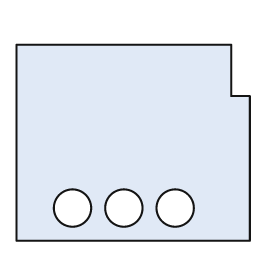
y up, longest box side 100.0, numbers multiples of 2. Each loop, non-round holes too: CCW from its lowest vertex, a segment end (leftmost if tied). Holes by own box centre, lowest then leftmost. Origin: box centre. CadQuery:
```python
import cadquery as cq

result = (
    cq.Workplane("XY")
    .moveTo(-50.0, -42.0)
    .lineTo(50.0, -42.0)
    .lineTo(50.0, 20.0)
    .lineTo(42.0, 20.0)
    .lineTo(42.0, 42.0)
    .lineTo(-50.0, 42.0)
    .close()
    .moveTo(-26.0, -28.0)
    .circle(8.0)
    .moveTo(-4.0, -28.0)
    .circle(8.0)
    .moveTo(18.0, -28.0)
    .circle(8.0)
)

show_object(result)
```